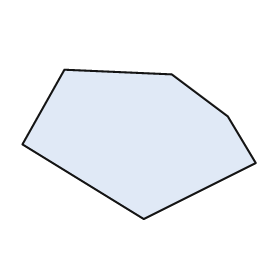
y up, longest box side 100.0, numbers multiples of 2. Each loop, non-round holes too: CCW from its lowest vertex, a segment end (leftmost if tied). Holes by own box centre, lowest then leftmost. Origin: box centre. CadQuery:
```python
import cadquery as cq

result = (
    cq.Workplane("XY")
    .moveTo(2.0, -32.0)
    .lineTo(50.0, -8.0)
    .lineTo(38.0, 12.0)
    .lineTo(14.0, 30.0)
    .lineTo(-32.0, 32.0)
    .lineTo(-50.0, 0.0)
    .close()
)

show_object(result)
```